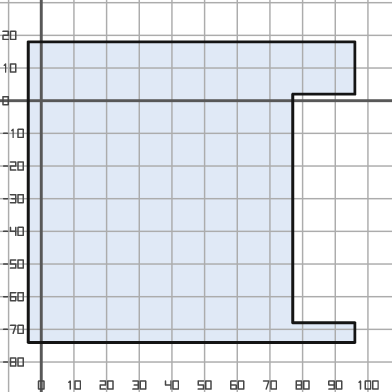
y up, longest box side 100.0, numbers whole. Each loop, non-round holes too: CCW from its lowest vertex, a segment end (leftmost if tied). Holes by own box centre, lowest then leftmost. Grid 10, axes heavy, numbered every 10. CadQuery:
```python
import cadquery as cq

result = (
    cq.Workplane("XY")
    .moveTo(-4.0, -74.0)
    .lineTo(96.0, -74.0)
    .lineTo(96.0, -68.0)
    .lineTo(77.0, -68.0)
    .lineTo(77.0, 2.0)
    .lineTo(96.0, 2.0)
    .lineTo(96.0, 18.0)
    .lineTo(-4.0, 18.0)
    .close()
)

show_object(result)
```